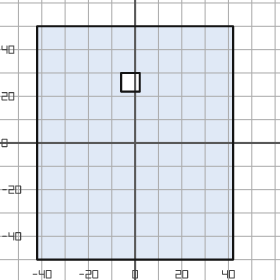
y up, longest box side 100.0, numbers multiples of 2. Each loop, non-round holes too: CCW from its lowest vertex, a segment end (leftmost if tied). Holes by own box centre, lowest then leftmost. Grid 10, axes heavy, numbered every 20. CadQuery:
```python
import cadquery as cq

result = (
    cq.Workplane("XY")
    .moveTo(-42.0, -50.0)
    .lineTo(42.0, -50.0)
    .lineTo(42.0, 50.0)
    .lineTo(-42.0, 50.0)
    .close()
    .moveTo(-6.0, 22.0)
    .lineTo(2.0, 22.0)
    .lineTo(2.0, 30.0)
    .lineTo(-6.0, 30.0)
    .close()
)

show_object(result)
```